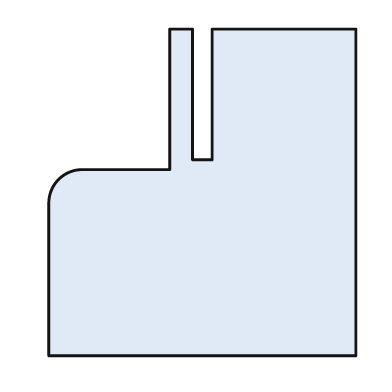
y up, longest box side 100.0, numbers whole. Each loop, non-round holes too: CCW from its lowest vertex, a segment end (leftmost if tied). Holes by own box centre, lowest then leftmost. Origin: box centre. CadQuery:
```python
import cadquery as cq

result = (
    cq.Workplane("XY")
    .moveTo(-47.0, -50.0)
    .lineTo(47.0, -50.0)
    .lineTo(47.0, 50.0)
    .lineTo(3.0, 50.0)
    .lineTo(3.0, 10.0)
    .lineTo(-3.0, 10.0)
    .lineTo(-3.0, 50.0)
    .lineTo(-10.0, 50.0)
    .lineTo(-10.0, 7.0)
    .lineTo(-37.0, 7.0)
    .threePointArc((-44.0, 4.0), (-47.0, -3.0))
    .close()
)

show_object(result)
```